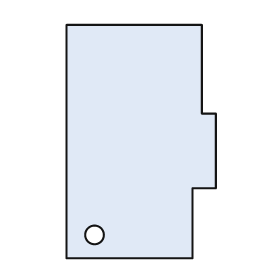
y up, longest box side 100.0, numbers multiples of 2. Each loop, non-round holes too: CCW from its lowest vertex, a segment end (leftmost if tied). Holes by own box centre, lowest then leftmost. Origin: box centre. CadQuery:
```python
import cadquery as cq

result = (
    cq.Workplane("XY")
    .moveTo(-32.0, -50.0)
    .lineTo(22.0, -50.0)
    .lineTo(22.0, -20.0)
    .lineTo(32.0, -20.0)
    .lineTo(32.0, 12.0)
    .lineTo(26.0, 12.0)
    .lineTo(26.0, 50.0)
    .lineTo(-32.0, 50.0)
    .close()
    .moveTo(-20.0, -40.0)
    .circle(4.0)
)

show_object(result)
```